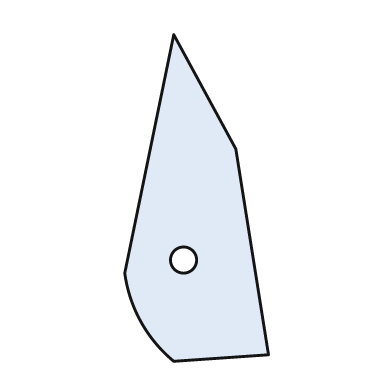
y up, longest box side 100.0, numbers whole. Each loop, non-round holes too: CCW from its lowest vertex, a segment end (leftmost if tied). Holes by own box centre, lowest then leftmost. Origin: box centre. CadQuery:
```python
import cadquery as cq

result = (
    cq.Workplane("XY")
    .moveTo(-7.0, -50.0)
    .lineTo(22.0, -48.0)
    .lineTo(12.0, 15.0)
    .lineTo(-7.0, 50.0)
    .lineTo(-22.0, -23.0)
    .threePointArc((-17.0, -38.0), (-7.0, -50.0))
    .close()
    .moveTo(-4.0, -19.0)
    .circle(4.0)
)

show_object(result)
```